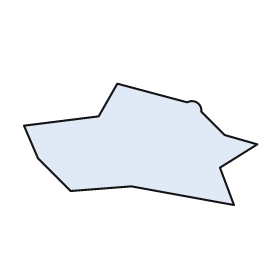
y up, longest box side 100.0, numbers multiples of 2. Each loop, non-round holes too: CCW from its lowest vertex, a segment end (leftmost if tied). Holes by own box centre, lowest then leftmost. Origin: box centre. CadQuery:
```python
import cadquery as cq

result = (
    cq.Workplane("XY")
    .moveTo(40.0, -26.0)
    .lineTo(34.0, -10.0)
    .lineTo(50.0, 0.0)
    .lineTo(36.0, 4.0)
    .lineTo(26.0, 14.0)
    .threePointArc((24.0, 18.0), (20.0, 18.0))
    .lineTo(-10.0, 26.0)
    .lineTo(-18.0, 12.0)
    .lineTo(-50.0, 8.0)
    .lineTo(-44.0, -6.0)
    .lineTo(-30.0, -20.0)
    .lineTo(-4.0, -18.0)
    .close()
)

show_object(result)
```